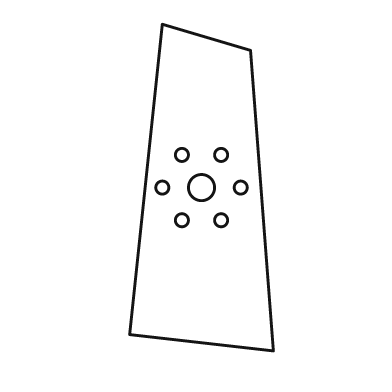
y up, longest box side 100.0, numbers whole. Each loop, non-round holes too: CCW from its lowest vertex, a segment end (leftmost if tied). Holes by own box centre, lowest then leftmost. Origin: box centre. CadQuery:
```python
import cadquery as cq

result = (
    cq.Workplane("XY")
    .moveTo(22.0, -50.0)
    .lineTo(15.0, 42.0)
    .lineTo(-12.0, 50.0)
    .lineTo(-22.0, -45.0)
    .close()
    .moveTo(-6.0, -10.0)
    .circle(2.0)
    .moveTo(6.0, -10.0)
    .circle(2.0)
    .moveTo(-12.0, 0.0)
    .circle(2.0)
    .moveTo(0.0, 0.0)
    .circle(4.0)
    .moveTo(12.0, 0.0)
    .circle(2.0)
    .moveTo(-6.0, 10.0)
    .circle(2.0)
    .moveTo(6.0, 10.0)
    .circle(2.0)
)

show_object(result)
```